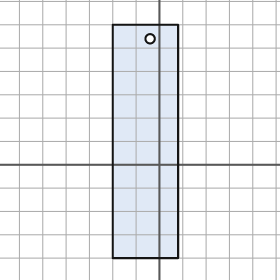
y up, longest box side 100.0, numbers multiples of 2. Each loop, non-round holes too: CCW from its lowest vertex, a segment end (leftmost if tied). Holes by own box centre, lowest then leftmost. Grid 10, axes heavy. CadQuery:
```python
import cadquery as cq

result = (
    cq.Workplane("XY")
    .moveTo(-20.0, -40.0)
    .lineTo(8.0, -40.0)
    .lineTo(8.0, 60.0)
    .lineTo(-20.0, 60.0)
    .close()
    .moveTo(-4.0, 54.0)
    .circle(2.0)
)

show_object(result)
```